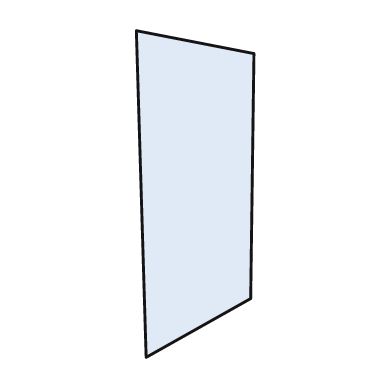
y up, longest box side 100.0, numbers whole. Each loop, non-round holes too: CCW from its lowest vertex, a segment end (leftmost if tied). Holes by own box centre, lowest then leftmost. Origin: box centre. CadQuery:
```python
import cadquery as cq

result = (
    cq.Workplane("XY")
    .moveTo(-15.0, -50.0)
    .lineTo(17.0, -32.0)
    .lineTo(18.0, 43.0)
    .lineTo(-18.0, 50.0)
    .close()
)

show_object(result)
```